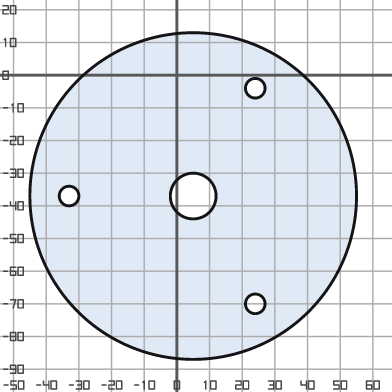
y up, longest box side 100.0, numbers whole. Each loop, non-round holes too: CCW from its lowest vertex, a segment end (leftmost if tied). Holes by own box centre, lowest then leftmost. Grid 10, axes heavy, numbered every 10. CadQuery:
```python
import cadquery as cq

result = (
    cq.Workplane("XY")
    .moveTo(5.0, -37.0)
    .circle(50.0)
    .moveTo(24.0, -70.0)
    .circle(3.0)
    .moveTo(-33.0, -37.0)
    .circle(3.0)
    .moveTo(5.0, -37.0)
    .circle(7.0)
    .moveTo(24.0, -4.0)
    .circle(3.0)
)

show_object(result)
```